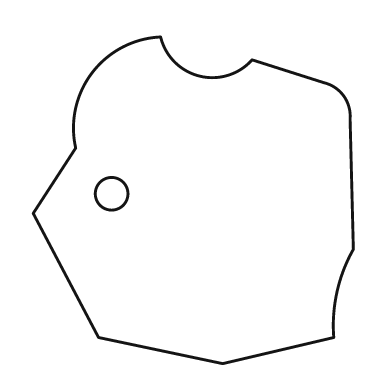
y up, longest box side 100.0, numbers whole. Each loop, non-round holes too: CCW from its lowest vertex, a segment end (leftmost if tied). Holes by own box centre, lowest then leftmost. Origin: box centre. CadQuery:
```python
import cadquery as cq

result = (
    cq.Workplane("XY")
    .moveTo(9.0, -50.0)
    .lineTo(43.0, -42.0)
    .threePointArc((44.0, -28.0), (49.0, -15.0))
    .lineTo(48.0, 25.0)
    .threePointArc((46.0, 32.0), (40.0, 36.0))
    .lineTo(18.0, 43.0)
    .threePointArc((2.0, 38.0), (-10.0, 50.0))
    .threePointArc((-31.0, 39.0), (-36.0, 16.0))
    .lineTo(-49.0, -4.0)
    .lineTo(-29.0, -42.0)
    .close()
    .moveTo(-25.0, 2.0)
    .circle(5.0)
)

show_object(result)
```